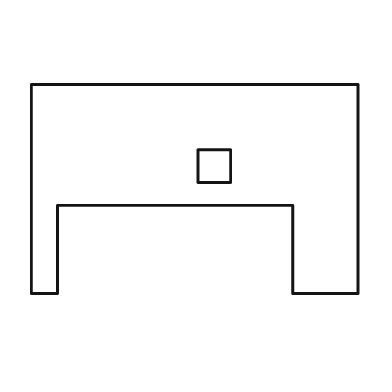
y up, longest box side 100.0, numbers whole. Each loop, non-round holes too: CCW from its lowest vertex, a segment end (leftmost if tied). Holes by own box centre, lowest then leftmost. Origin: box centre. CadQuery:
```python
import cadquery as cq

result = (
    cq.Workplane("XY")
    .moveTo(-50.0, -32.0)
    .lineTo(-42.0, -32.0)
    .lineTo(-42.0, -5.0)
    .lineTo(30.0, -5.0)
    .lineTo(30.0, -32.0)
    .lineTo(50.0, -32.0)
    .lineTo(50.0, 32.0)
    .lineTo(-50.0, 32.0)
    .close()
    .moveTo(1.0, 2.0)
    .lineTo(11.0, 2.0)
    .lineTo(11.0, 12.0)
    .lineTo(1.0, 12.0)
    .close()
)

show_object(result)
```